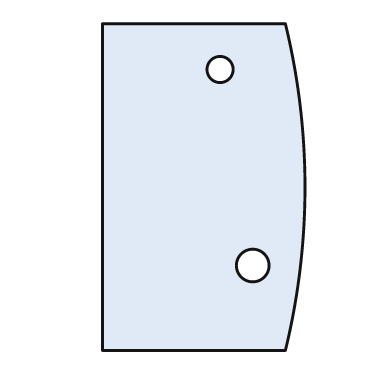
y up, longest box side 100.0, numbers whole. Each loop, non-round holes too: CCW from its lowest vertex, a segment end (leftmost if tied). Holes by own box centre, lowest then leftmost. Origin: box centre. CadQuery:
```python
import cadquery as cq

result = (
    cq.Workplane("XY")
    .moveTo(-31.0, -50.0)
    .lineTo(25.0, -50.0)
    .threePointArc((31.0, 0.0), (25.0, 50.0))
    .lineTo(-31.0, 50.0)
    .close()
    .moveTo(15.0, -24.0)
    .circle(5.0)
    .moveTo(5.0, 36.0)
    .circle(4.0)
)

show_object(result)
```